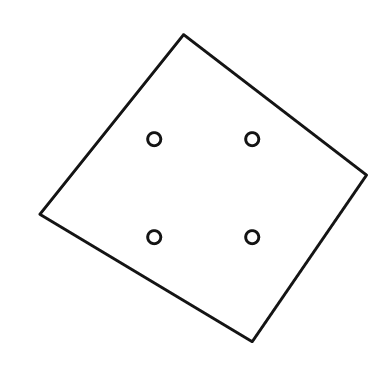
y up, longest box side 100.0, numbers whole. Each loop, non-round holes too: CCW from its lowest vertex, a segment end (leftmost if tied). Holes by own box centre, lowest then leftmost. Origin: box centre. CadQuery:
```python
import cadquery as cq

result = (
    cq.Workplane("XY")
    .moveTo(15.0, -47.0)
    .lineTo(50.0, 4.0)
    .lineTo(-6.0, 47.0)
    .lineTo(-50.0, -8.0)
    .close()
    .moveTo(-15.0, -15.0)
    .circle(2.0)
    .moveTo(15.0, -15.0)
    .circle(2.0)
    .moveTo(-15.0, 15.0)
    .circle(2.0)
    .moveTo(15.0, 15.0)
    .circle(2.0)
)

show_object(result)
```